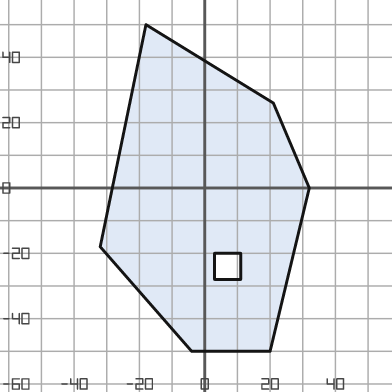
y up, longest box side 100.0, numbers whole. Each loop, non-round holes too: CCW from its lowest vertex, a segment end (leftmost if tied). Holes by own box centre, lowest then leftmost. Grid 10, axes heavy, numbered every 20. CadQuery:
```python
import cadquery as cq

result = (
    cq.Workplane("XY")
    .moveTo(-4.0, -50.0)
    .lineTo(20.0, -50.0)
    .lineTo(32.0, 0.0)
    .lineTo(21.0, 26.0)
    .lineTo(-18.0, 50.0)
    .lineTo(-32.0, -18.0)
    .close()
    .moveTo(3.0, -28.0)
    .lineTo(11.0, -28.0)
    .lineTo(11.0, -20.0)
    .lineTo(3.0, -20.0)
    .close()
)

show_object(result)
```